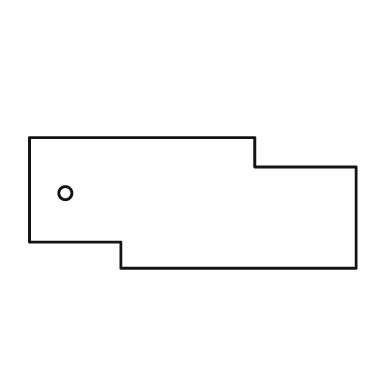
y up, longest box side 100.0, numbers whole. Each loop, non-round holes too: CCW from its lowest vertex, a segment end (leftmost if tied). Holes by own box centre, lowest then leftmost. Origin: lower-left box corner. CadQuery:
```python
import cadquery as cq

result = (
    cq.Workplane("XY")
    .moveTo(28.0, 0.0)
    .lineTo(100.0, 0.0)
    .lineTo(100.0, 31.0)
    .lineTo(69.0, 31.0)
    .lineTo(69.0, 40.0)
    .lineTo(0.0, 40.0)
    .lineTo(0.0, 8.0)
    .lineTo(28.0, 8.0)
    .close()
    .moveTo(11.0, 23.0)
    .circle(2.0)
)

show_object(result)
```